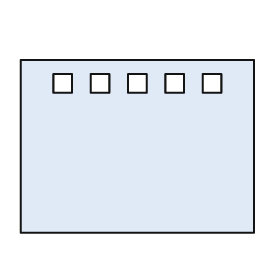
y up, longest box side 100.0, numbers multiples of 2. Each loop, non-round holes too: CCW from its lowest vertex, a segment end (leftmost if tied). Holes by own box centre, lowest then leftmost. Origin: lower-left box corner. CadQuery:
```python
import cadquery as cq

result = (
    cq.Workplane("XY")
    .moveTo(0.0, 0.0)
    .lineTo(100.0, 0.0)
    .lineTo(100.0, 74.0)
    .lineTo(0.0, 74.0)
    .close()
    .moveTo(14.0, 60.0)
    .lineTo(22.0, 60.0)
    .lineTo(22.0, 68.0)
    .lineTo(14.0, 68.0)
    .close()
    .moveTo(30.0, 60.0)
    .lineTo(38.0, 60.0)
    .lineTo(38.0, 68.0)
    .lineTo(30.0, 68.0)
    .close()
    .moveTo(46.0, 60.0)
    .lineTo(54.0, 60.0)
    .lineTo(54.0, 68.0)
    .lineTo(46.0, 68.0)
    .close()
    .moveTo(62.0, 60.0)
    .lineTo(70.0, 60.0)
    .lineTo(70.0, 68.0)
    .lineTo(62.0, 68.0)
    .close()
    .moveTo(78.0, 60.0)
    .lineTo(86.0, 60.0)
    .lineTo(86.0, 68.0)
    .lineTo(78.0, 68.0)
    .close()
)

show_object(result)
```